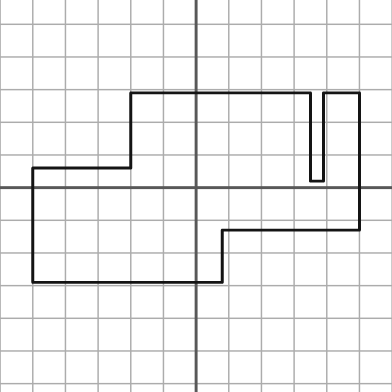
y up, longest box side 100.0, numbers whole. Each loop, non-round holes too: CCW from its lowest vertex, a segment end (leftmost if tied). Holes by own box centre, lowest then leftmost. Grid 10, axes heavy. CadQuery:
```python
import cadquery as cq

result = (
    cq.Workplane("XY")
    .moveTo(-50.0, -29.0)
    .lineTo(8.0, -29.0)
    .lineTo(8.0, -13.0)
    .lineTo(50.0, -13.0)
    .lineTo(50.0, 29.0)
    .lineTo(39.0, 29.0)
    .lineTo(39.0, 2.0)
    .lineTo(35.0, 2.0)
    .lineTo(35.0, 29.0)
    .lineTo(-20.0, 29.0)
    .lineTo(-20.0, 6.0)
    .lineTo(-50.0, 6.0)
    .close()
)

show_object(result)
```